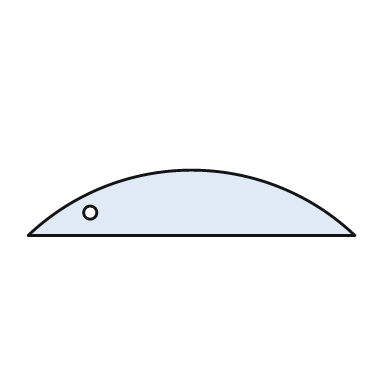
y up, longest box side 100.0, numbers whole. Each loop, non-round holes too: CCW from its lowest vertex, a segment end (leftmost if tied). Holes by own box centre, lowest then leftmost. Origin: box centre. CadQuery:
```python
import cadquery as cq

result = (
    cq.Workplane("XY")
    .moveTo(-50.0, -10.0)
    .lineTo(50.0, -10.0)
    .threePointArc((0.0, 10.0), (-50.0, -10.0))
    .close()
    .moveTo(-31.0, -3.0)
    .circle(2.0)
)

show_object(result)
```